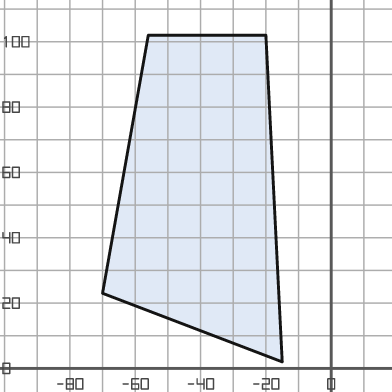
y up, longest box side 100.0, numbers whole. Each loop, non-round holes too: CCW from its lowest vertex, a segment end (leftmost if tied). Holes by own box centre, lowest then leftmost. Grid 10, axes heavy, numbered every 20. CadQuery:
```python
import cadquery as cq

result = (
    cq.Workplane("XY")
    .moveTo(-15.0, 2.0)
    .lineTo(-20.0, 102.0)
    .lineTo(-56.0, 102.0)
    .lineTo(-70.0, 23.0)
    .close()
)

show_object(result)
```